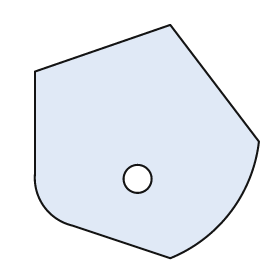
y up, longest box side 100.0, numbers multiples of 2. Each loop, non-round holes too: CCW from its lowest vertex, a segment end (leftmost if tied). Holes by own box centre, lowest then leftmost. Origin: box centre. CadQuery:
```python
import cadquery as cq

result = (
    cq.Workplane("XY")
    .moveTo(10.0, -50.0)
    .threePointArc((36.0, -30.0), (48.0, 0.0))
    .lineTo(10.0, 50.0)
    .lineTo(-48.0, 30.0)
    .lineTo(-48.0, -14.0)
    .threePointArc((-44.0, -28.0), (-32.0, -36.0))
    .close()
    .moveTo(-4.0, -16.0)
    .circle(6.0)
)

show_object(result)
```